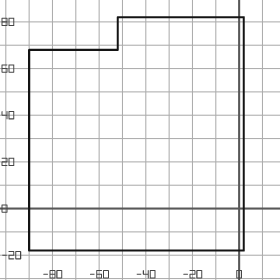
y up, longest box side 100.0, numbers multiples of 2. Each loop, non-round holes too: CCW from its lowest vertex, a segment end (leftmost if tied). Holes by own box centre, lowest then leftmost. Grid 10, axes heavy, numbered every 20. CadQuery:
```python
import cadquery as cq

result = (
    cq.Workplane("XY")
    .moveTo(-90.0, -18.0)
    .lineTo(2.0, -18.0)
    .lineTo(2.0, 82.0)
    .lineTo(-52.0, 82.0)
    .lineTo(-52.0, 68.0)
    .lineTo(-90.0, 68.0)
    .close()
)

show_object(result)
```